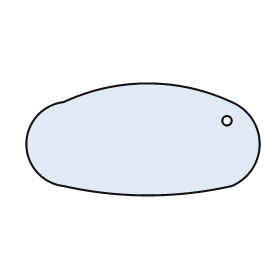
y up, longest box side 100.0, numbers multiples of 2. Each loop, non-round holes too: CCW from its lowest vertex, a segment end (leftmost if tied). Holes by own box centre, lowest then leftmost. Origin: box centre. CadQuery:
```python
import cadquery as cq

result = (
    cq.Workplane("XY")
    .moveTo(-34.0, -20.0)
    .threePointArc((2.0, -24.0), (38.0, -20.0))
    .threePointArc((50.0, -2.0), (38.0, 16.0))
    .threePointArc((2.0, 24.0), (-34.0, 16.0))
    .threePointArc((-50.0, -2.0), (-34.0, -20.0))
    .close()
    .moveTo(36.0, 8.0)
    .circle(2.0)
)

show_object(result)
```